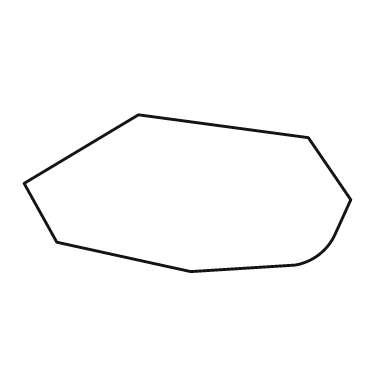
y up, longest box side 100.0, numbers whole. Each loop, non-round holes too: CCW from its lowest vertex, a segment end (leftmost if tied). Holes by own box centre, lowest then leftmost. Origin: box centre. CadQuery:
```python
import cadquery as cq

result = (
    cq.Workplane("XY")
    .moveTo(1.0, -24.0)
    .lineTo(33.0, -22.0)
    .threePointArc((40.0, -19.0), (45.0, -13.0))
    .lineTo(50.0, -2.0)
    .lineTo(37.0, 17.0)
    .lineTo(-15.0, 24.0)
    .lineTo(-50.0, 3.0)
    .lineTo(-40.0, -15.0)
    .close()
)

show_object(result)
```